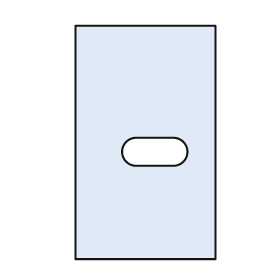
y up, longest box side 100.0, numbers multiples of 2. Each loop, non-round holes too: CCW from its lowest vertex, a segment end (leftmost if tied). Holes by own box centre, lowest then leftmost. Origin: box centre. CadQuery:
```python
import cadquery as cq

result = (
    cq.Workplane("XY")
    .moveTo(-30.0, -50.0)
    .lineTo(30.0, -50.0)
    .lineTo(30.0, 50.0)
    .lineTo(-30.0, 50.0)
    .close()
    .moveTo(-4.0, -10.0)
    .lineTo(12.0, -10.0)
    .threePointArc((18.0, -4.0), (12.0, 2.0))
    .lineTo(-4.0, 2.0)
    .threePointArc((-10.0, -4.0), (-4.0, -10.0))
    .close()
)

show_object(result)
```